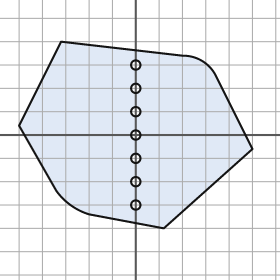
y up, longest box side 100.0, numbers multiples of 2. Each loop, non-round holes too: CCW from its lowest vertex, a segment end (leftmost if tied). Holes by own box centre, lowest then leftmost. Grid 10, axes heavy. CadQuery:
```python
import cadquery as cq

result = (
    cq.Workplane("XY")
    .moveTo(12.0, -40.0)
    .lineTo(50.0, -6.0)
    .lineTo(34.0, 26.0)
    .threePointArc((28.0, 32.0), (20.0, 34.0))
    .lineTo(-32.0, 40.0)
    .lineTo(-50.0, 4.0)
    .lineTo(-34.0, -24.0)
    .threePointArc((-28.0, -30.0), (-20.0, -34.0))
    .close()
    .moveTo(0.0, -30.0)
    .circle(2.0)
    .moveTo(0.0, -20.0)
    .circle(2.0)
    .moveTo(0.0, -10.0)
    .circle(2.0)
    .moveTo(0.0, 0.0)
    .circle(2.0)
    .moveTo(0.0, 10.0)
    .circle(2.0)
    .moveTo(0.0, 20.0)
    .circle(2.0)
    .moveTo(0.0, 30.0)
    .circle(2.0)
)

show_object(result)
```